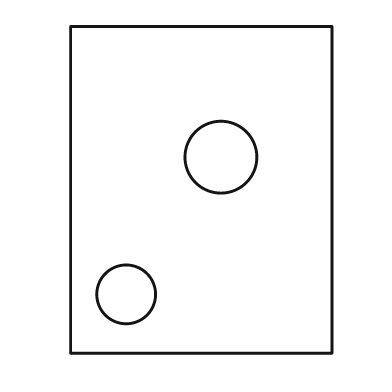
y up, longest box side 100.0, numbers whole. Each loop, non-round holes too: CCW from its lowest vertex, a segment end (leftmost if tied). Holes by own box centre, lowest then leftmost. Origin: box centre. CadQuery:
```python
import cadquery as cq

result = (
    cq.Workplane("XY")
    .moveTo(-40.0, -50.0)
    .lineTo(40.0, -50.0)
    .lineTo(40.0, 50.0)
    .lineTo(-40.0, 50.0)
    .close()
    .moveTo(-23.0, -32.0)
    .circle(9.0)
    .moveTo(6.0, 10.0)
    .circle(11.0)
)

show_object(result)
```